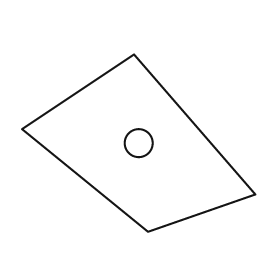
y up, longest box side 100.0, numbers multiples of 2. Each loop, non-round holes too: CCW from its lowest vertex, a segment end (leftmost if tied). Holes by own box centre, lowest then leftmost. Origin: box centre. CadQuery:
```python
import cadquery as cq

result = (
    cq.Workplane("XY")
    .moveTo(4.0, -38.0)
    .lineTo(50.0, -22.0)
    .lineTo(-2.0, 38.0)
    .lineTo(-50.0, 6.0)
    .close()
    .moveTo(0.0, 0.0)
    .circle(6.0)
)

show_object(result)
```